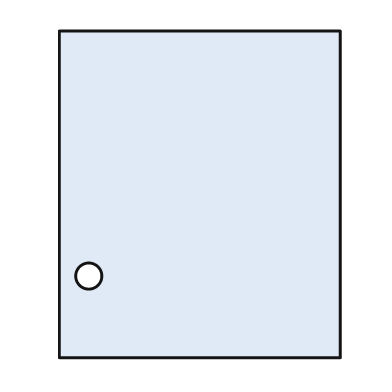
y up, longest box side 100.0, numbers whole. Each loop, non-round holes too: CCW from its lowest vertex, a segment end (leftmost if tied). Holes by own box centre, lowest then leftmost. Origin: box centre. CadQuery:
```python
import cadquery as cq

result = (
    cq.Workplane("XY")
    .moveTo(-43.0, -50.0)
    .lineTo(43.0, -50.0)
    .lineTo(43.0, 50.0)
    .lineTo(-43.0, 50.0)
    .close()
    .moveTo(-34.0, -25.0)
    .circle(4.0)
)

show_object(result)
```